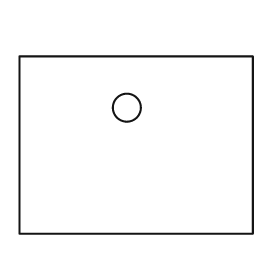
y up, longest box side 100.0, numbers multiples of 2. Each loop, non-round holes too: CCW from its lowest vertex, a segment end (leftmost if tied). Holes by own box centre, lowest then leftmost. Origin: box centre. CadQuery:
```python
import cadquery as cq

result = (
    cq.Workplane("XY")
    .moveTo(-50.0, -38.0)
    .lineTo(50.0, -38.0)
    .lineTo(50.0, 38.0)
    .lineTo(-50.0, 38.0)
    .close()
    .moveTo(-4.0, 16.0)
    .circle(6.0)
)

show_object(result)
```